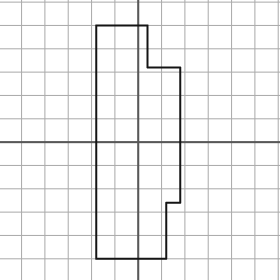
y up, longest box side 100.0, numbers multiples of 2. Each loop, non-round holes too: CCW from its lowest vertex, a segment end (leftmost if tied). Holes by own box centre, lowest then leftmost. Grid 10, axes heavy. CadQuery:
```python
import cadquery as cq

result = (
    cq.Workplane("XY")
    .moveTo(-18.0, -50.0)
    .lineTo(12.0, -50.0)
    .lineTo(12.0, -26.0)
    .lineTo(18.0, -26.0)
    .lineTo(18.0, 32.0)
    .lineTo(4.0, 32.0)
    .lineTo(4.0, 50.0)
    .lineTo(-18.0, 50.0)
    .close()
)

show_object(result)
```